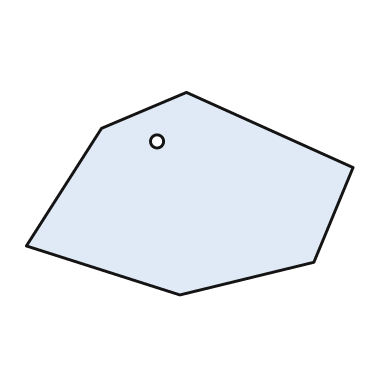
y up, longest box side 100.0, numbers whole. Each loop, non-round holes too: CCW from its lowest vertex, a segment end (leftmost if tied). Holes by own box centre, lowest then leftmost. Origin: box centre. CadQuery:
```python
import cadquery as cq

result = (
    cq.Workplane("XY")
    .moveTo(-3.0, -31.0)
    .lineTo(38.0, -21.0)
    .lineTo(50.0, 8.0)
    .lineTo(-1.0, 31.0)
    .lineTo(-27.0, 20.0)
    .lineTo(-50.0, -16.0)
    .close()
    .moveTo(-10.0, 16.0)
    .circle(2.0)
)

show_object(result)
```